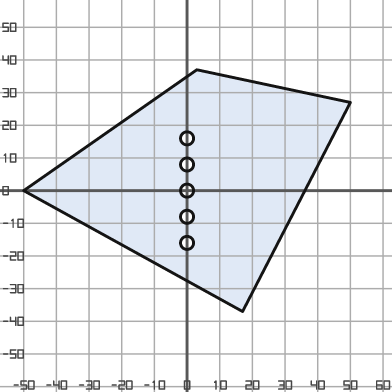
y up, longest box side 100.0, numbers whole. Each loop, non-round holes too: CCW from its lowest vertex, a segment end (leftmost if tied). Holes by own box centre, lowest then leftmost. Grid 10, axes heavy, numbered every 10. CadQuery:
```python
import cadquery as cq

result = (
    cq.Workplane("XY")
    .moveTo(17.0, -37.0)
    .lineTo(50.0, 27.0)
    .lineTo(3.0, 37.0)
    .lineTo(-50.0, 0.0)
    .close()
    .moveTo(0.0, -16.0)
    .circle(2.0)
    .moveTo(0.0, -8.0)
    .circle(2.0)
    .moveTo(0.0, 0.0)
    .circle(2.0)
    .moveTo(0.0, 8.0)
    .circle(2.0)
    .moveTo(0.0, 16.0)
    .circle(2.0)
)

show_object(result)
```